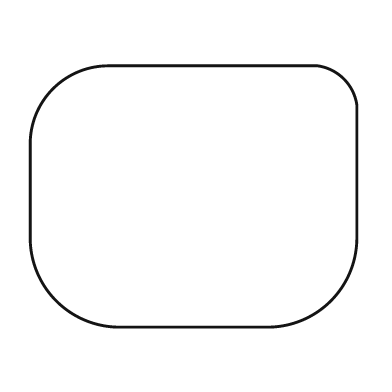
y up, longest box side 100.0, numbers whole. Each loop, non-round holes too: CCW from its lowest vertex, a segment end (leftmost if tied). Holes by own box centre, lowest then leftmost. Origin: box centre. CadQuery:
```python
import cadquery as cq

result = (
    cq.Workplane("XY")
    .moveTo(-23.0, -40.0)
    .lineTo(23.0, -40.0)
    .threePointArc((42.0, -32.0), (50.0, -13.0))
    .lineTo(50.0, 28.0)
    .threePointArc((46.0, 36.0), (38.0, 40.0))
    .lineTo(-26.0, 40.0)
    .threePointArc((-43.0, 33.0), (-50.0, 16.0))
    .lineTo(-50.0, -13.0)
    .threePointArc((-42.0, -32.0), (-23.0, -40.0))
    .close()
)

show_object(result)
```